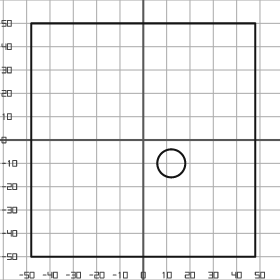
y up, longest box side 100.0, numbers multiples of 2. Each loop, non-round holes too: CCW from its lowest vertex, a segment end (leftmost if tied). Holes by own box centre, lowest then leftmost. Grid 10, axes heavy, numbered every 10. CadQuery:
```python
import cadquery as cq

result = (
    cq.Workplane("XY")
    .moveTo(-48.0, -50.0)
    .lineTo(48.0, -50.0)
    .lineTo(48.0, 50.0)
    .lineTo(-48.0, 50.0)
    .close()
    .moveTo(12.0, -10.0)
    .circle(6.0)
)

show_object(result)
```